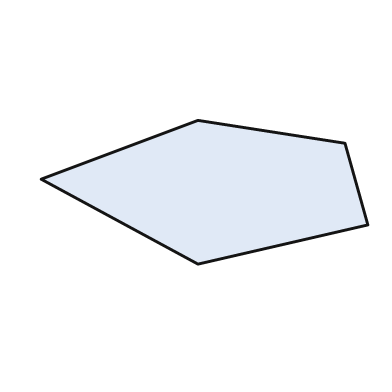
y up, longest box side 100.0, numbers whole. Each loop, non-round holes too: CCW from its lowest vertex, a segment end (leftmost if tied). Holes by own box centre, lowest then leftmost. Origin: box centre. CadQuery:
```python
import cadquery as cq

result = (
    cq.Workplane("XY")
    .moveTo(-2.0, -22.0)
    .lineTo(50.0, -10.0)
    .lineTo(43.0, 15.0)
    .lineTo(-2.0, 22.0)
    .lineTo(-50.0, 4.0)
    .close()
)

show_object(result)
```